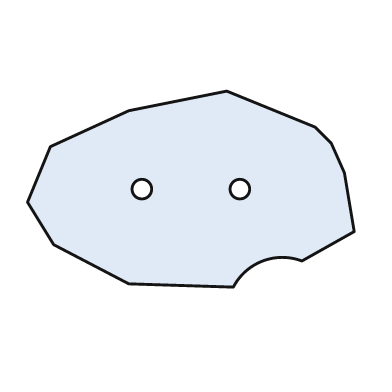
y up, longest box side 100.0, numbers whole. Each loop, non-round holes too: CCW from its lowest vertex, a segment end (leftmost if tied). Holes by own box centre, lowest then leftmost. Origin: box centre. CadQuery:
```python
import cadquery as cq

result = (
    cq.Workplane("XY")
    .moveTo(13.0, -30.0)
    .threePointArc((22.0, -22.0), (34.0, -22.0))
    .lineTo(50.0, -13.0)
    .lineTo(47.0, 5.0)
    .lineTo(43.0, 14.0)
    .lineTo(38.0, 19.0)
    .lineTo(11.0, 30.0)
    .lineTo(-19.0, 24.0)
    .lineTo(-43.0, 13.0)
    .lineTo(-50.0, -4.0)
    .lineTo(-42.0, -17.0)
    .lineTo(-19.0, -29.0)
    .close()
    .moveTo(-15.0, 0.0)
    .circle(3.0)
    .moveTo(15.0, 0.0)
    .circle(3.0)
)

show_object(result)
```